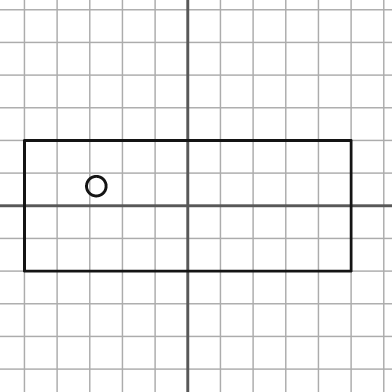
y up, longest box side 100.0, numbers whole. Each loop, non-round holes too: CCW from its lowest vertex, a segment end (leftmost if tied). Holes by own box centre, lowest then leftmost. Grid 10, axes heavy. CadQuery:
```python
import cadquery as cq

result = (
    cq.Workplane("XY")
    .moveTo(-50.0, -20.0)
    .lineTo(50.0, -20.0)
    .lineTo(50.0, 20.0)
    .lineTo(-50.0, 20.0)
    .close()
    .moveTo(-28.0, 6.0)
    .circle(3.0)
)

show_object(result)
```